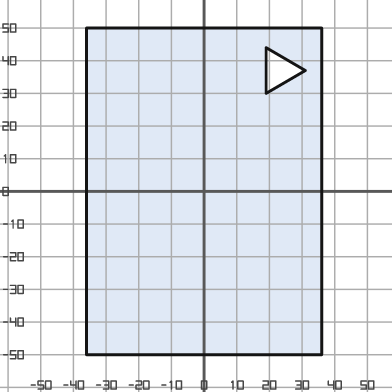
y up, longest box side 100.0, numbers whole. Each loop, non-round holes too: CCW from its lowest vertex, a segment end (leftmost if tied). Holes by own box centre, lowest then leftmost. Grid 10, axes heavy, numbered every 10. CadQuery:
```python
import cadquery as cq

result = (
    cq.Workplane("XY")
    .moveTo(-36.0, -50.0)
    .lineTo(36.0, -50.0)
    .lineTo(36.0, 50.0)
    .lineTo(-36.0, 50.0)
    .close()
    .moveTo(19.0, 30.0)
    .lineTo(31.0, 37.0)
    .lineTo(19.0, 44.0)
    .close()
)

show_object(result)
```